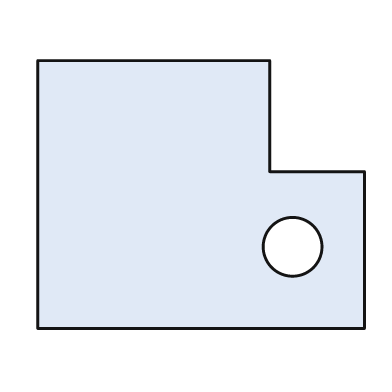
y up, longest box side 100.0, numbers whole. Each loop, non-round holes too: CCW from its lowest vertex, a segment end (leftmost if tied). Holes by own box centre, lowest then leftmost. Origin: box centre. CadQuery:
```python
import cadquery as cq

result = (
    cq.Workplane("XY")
    .moveTo(-50.0, -41.0)
    .lineTo(50.0, -41.0)
    .lineTo(50.0, 7.0)
    .lineTo(21.0, 7.0)
    .lineTo(21.0, 41.0)
    .lineTo(-50.0, 41.0)
    .close()
    .moveTo(28.0, -16.0)
    .circle(9.0)
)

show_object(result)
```